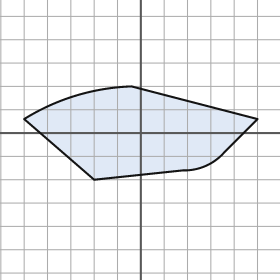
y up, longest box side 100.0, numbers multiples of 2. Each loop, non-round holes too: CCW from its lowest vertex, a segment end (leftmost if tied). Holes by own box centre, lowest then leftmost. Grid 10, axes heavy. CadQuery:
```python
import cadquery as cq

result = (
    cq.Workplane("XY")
    .moveTo(-20.0, -20.0)
    .lineTo(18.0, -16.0)
    .threePointArc((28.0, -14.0), (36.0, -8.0))
    .lineTo(50.0, 6.0)
    .lineTo(-4.0, 20.0)
    .threePointArc((-28.0, 16.0), (-50.0, 6.0))
    .close()
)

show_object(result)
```